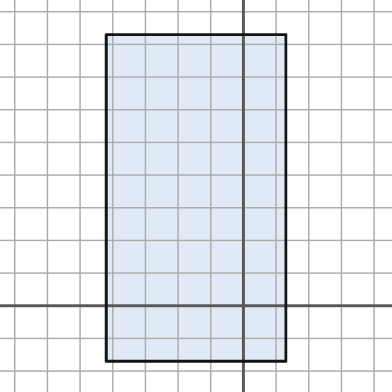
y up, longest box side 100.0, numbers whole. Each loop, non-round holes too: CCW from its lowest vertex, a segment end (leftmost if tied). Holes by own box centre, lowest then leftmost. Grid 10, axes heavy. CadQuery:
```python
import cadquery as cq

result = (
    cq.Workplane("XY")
    .moveTo(-42.0, -17.0)
    .lineTo(13.0, -17.0)
    .lineTo(13.0, 83.0)
    .lineTo(-42.0, 83.0)
    .close()
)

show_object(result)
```